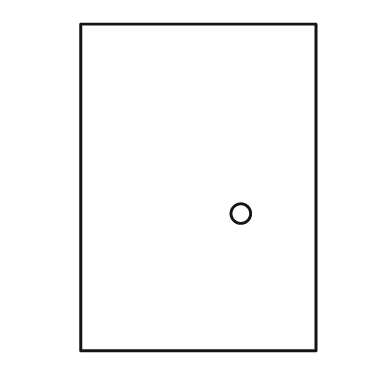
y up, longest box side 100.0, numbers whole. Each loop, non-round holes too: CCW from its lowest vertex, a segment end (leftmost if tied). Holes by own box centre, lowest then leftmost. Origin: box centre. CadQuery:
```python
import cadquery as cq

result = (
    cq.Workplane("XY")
    .moveTo(-36.0, -50.0)
    .lineTo(36.0, -50.0)
    .lineTo(36.0, 50.0)
    .lineTo(-36.0, 50.0)
    .close()
    .moveTo(13.0, -8.0)
    .circle(3.0)
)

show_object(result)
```